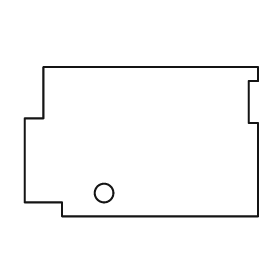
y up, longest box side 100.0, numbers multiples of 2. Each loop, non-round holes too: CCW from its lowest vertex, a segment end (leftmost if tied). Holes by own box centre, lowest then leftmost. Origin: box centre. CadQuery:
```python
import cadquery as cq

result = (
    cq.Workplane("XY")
    .moveTo(-34.0, -32.0)
    .lineTo(50.0, -32.0)
    .lineTo(50.0, 8.0)
    .lineTo(46.0, 8.0)
    .lineTo(46.0, 26.0)
    .lineTo(50.0, 26.0)
    .lineTo(50.0, 32.0)
    .lineTo(-42.0, 32.0)
    .lineTo(-42.0, 10.0)
    .lineTo(-50.0, 10.0)
    .lineTo(-50.0, -26.0)
    .lineTo(-34.0, -26.0)
    .close()
    .moveTo(-16.0, -22.0)
    .circle(4.0)
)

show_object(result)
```